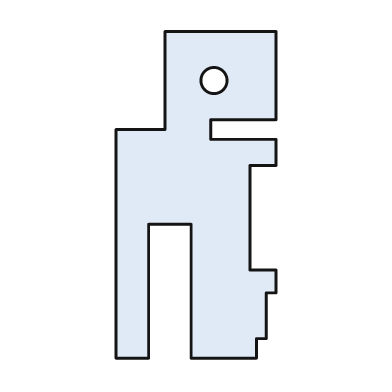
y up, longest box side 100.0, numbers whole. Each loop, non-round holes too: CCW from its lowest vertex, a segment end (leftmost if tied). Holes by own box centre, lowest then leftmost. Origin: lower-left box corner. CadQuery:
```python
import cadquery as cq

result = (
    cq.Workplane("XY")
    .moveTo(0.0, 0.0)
    .lineTo(10.0, 0.0)
    .lineTo(10.0, 41.0)
    .lineTo(23.0, 41.0)
    .lineTo(23.0, 0.0)
    .lineTo(43.0, 0.0)
    .lineTo(43.0, 6.0)
    .lineTo(46.0, 6.0)
    .lineTo(46.0, 20.0)
    .lineTo(49.0, 20.0)
    .lineTo(49.0, 27.0)
    .lineTo(41.0, 27.0)
    .lineTo(41.0, 59.0)
    .lineTo(49.0, 59.0)
    .lineTo(49.0, 67.0)
    .lineTo(29.0, 67.0)
    .lineTo(29.0, 73.0)
    .lineTo(49.0, 73.0)
    .lineTo(49.0, 100.0)
    .lineTo(15.0, 100.0)
    .lineTo(15.0, 70.0)
    .lineTo(0.0, 70.0)
    .close()
    .moveTo(30.0, 85.0)
    .circle(4.0)
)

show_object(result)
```